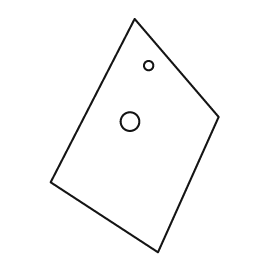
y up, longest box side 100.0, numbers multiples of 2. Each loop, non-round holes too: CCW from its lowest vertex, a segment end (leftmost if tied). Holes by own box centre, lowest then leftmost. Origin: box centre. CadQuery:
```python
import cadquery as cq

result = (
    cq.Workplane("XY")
    .moveTo(10.0, -50.0)
    .lineTo(36.0, 8.0)
    .lineTo(0.0, 50.0)
    .lineTo(-36.0, -20.0)
    .close()
    .moveTo(-2.0, 6.0)
    .circle(4.0)
    .moveTo(6.0, 30.0)
    .circle(2.0)
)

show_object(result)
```